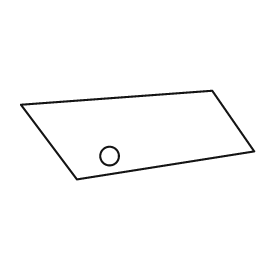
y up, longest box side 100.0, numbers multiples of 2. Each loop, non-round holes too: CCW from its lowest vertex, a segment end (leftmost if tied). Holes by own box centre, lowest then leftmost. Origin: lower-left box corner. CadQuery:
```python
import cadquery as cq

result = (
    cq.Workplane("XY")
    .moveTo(24.0, 0.0)
    .lineTo(100.0, 12.0)
    .lineTo(82.0, 38.0)
    .lineTo(0.0, 32.0)
    .close()
    .moveTo(38.0, 10.0)
    .circle(4.0)
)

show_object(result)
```